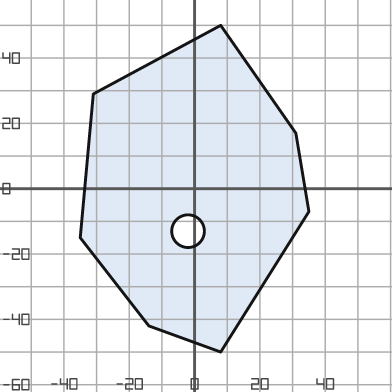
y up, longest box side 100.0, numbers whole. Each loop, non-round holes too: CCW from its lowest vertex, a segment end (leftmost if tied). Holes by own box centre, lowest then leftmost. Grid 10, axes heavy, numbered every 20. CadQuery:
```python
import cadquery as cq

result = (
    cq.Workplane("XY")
    .moveTo(8.0, -50.0)
    .lineTo(35.0, -7.0)
    .lineTo(31.0, 17.0)
    .lineTo(8.0, 50.0)
    .lineTo(-31.0, 29.0)
    .lineTo(-35.0, -15.0)
    .lineTo(-14.0, -42.0)
    .close()
    .moveTo(-2.0, -13.0)
    .circle(5.0)
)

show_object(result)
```